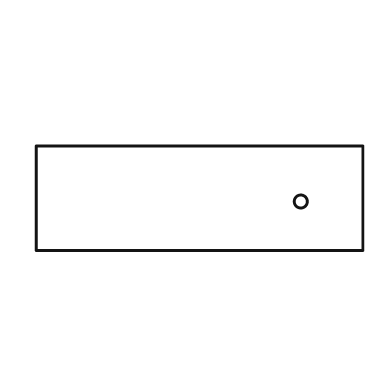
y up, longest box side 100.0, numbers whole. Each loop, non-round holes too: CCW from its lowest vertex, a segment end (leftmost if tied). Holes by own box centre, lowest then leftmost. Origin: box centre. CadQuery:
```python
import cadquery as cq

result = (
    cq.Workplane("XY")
    .moveTo(-50.0, -16.0)
    .lineTo(50.0, -16.0)
    .lineTo(50.0, 16.0)
    .lineTo(-50.0, 16.0)
    .close()
    .moveTo(31.0, -1.0)
    .circle(2.0)
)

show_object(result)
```